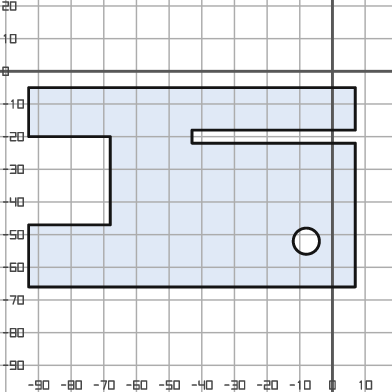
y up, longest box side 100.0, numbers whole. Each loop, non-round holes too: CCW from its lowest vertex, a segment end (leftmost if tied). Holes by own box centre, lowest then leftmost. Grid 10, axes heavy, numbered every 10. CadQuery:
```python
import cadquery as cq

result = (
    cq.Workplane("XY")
    .moveTo(-93.0, -66.0)
    .lineTo(7.0, -66.0)
    .lineTo(7.0, -22.0)
    .lineTo(-43.0, -22.0)
    .lineTo(-43.0, -18.0)
    .lineTo(7.0, -18.0)
    .lineTo(7.0, -5.0)
    .lineTo(-93.0, -5.0)
    .lineTo(-93.0, -20.0)
    .lineTo(-68.0, -20.0)
    .lineTo(-68.0, -47.0)
    .lineTo(-93.0, -47.0)
    .close()
    .moveTo(-8.0, -52.0)
    .circle(4.0)
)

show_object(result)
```